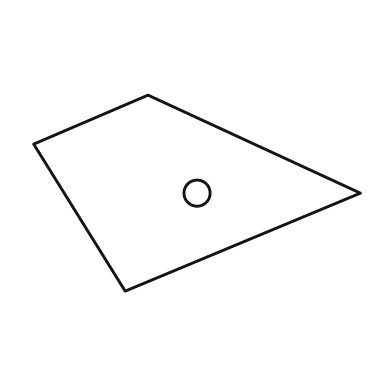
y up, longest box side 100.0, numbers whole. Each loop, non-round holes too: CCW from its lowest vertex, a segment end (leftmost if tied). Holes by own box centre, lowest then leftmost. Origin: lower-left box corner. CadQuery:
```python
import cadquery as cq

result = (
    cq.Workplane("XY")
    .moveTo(28.0, 0.0)
    .lineTo(100.0, 30.0)
    .lineTo(35.0, 60.0)
    .lineTo(0.0, 45.0)
    .close()
    .moveTo(50.0, 30.0)
    .circle(4.0)
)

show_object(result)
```